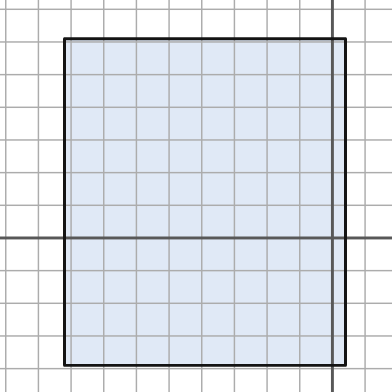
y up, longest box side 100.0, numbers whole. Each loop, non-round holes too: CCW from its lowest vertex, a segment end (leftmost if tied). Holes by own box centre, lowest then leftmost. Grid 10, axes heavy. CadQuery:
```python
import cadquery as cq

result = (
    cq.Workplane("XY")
    .moveTo(-82.0, -39.0)
    .lineTo(4.0, -39.0)
    .lineTo(4.0, 61.0)
    .lineTo(-82.0, 61.0)
    .close()
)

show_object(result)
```